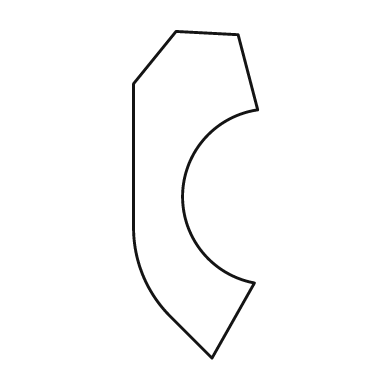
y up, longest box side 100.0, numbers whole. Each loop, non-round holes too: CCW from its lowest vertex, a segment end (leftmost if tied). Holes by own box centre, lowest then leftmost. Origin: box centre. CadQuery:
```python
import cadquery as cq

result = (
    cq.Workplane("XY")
    .moveTo(5.0, -50.0)
    .lineTo(18.0, -27.0)
    .threePointArc((-4.0, 0.0), (19.0, 26.0))
    .lineTo(13.0, 49.0)
    .lineTo(-6.0, 50.0)
    .lineTo(-19.0, 34.0)
    .lineTo(-19.0, -11.0)
    .threePointArc((-16.0, -25.0), (-8.0, -37.0))
    .close()
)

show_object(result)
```